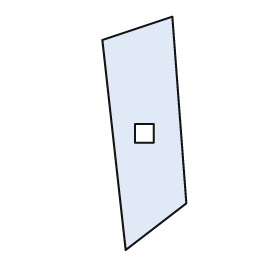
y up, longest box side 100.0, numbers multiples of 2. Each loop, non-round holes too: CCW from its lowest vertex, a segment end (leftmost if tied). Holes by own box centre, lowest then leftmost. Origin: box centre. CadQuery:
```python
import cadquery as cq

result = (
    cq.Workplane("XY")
    .moveTo(-8.0, -50.0)
    .lineTo(18.0, -30.0)
    .lineTo(12.0, 50.0)
    .lineTo(-18.0, 40.0)
    .close()
    .moveTo(-4.0, -4.0)
    .lineTo(4.0, -4.0)
    .lineTo(4.0, 4.0)
    .lineTo(-4.0, 4.0)
    .close()
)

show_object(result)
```